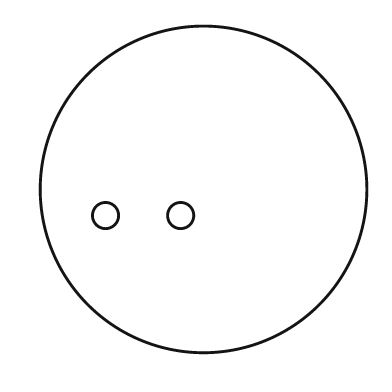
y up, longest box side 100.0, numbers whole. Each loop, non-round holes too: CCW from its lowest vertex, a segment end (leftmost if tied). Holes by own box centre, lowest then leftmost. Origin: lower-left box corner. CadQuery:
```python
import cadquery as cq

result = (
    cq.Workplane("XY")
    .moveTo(50.0, 50.0)
    .circle(50.0)
    .moveTo(20.0, 42.0)
    .circle(4.0)
    .moveTo(43.0, 42.0)
    .circle(4.0)
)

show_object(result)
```